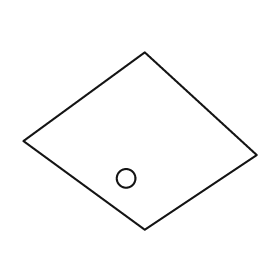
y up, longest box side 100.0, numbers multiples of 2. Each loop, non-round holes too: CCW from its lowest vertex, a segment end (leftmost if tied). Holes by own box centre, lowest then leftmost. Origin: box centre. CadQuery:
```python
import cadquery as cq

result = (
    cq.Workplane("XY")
    .moveTo(2.0, -38.0)
    .lineTo(50.0, -6.0)
    .lineTo(2.0, 38.0)
    .lineTo(-50.0, 0.0)
    .close()
    .moveTo(-6.0, -16.0)
    .circle(4.0)
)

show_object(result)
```